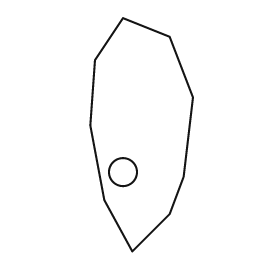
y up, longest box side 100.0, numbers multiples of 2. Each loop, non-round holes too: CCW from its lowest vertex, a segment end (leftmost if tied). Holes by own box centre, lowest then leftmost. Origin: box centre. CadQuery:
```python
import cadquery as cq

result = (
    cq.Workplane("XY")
    .moveTo(-4.0, -50.0)
    .lineTo(12.0, -34.0)
    .lineTo(18.0, -18.0)
    .lineTo(22.0, 16.0)
    .lineTo(12.0, 42.0)
    .lineTo(-8.0, 50.0)
    .lineTo(-20.0, 32.0)
    .lineTo(-22.0, 4.0)
    .lineTo(-16.0, -28.0)
    .close()
    .moveTo(-8.0, -16.0)
    .circle(6.0)
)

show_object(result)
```